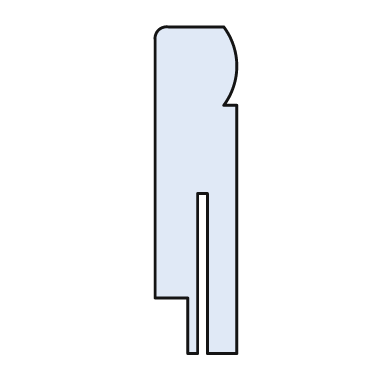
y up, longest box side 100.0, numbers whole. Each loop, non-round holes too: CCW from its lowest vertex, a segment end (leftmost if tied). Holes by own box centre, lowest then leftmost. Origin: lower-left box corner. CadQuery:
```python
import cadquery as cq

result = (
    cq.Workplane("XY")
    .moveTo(10.0, 0.0)
    .lineTo(13.0, 0.0)
    .lineTo(13.0, 49.0)
    .lineTo(16.0, 49.0)
    .lineTo(16.0, 0.0)
    .lineTo(25.0, 0.0)
    .lineTo(25.0, 76.0)
    .lineTo(21.0, 76.0)
    .threePointArc((25.0, 88.0), (21.0, 100.0))
    .lineTo(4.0, 100.0)
    .threePointArc((1.0, 99.0), (0.0, 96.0))
    .lineTo(0.0, 17.0)
    .lineTo(10.0, 17.0)
    .close()
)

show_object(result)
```